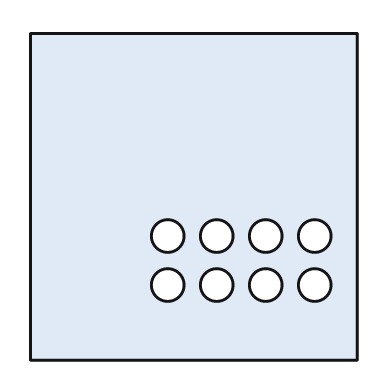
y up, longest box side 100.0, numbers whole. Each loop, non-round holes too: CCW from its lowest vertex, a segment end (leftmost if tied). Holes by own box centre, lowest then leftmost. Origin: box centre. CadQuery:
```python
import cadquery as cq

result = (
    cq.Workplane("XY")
    .moveTo(-50.0, -50.0)
    .lineTo(50.0, -50.0)
    .lineTo(50.0, 50.0)
    .lineTo(-50.0, 50.0)
    .close()
    .moveTo(-8.0, -27.0)
    .circle(5.0)
    .moveTo(7.0, -27.0)
    .circle(5.0)
    .moveTo(22.0, -27.0)
    .circle(5.0)
    .moveTo(37.0, -27.0)
    .circle(5.0)
    .moveTo(-8.0, -12.0)
    .circle(5.0)
    .moveTo(7.0, -12.0)
    .circle(5.0)
    .moveTo(22.0, -12.0)
    .circle(5.0)
    .moveTo(37.0, -12.0)
    .circle(5.0)
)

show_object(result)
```